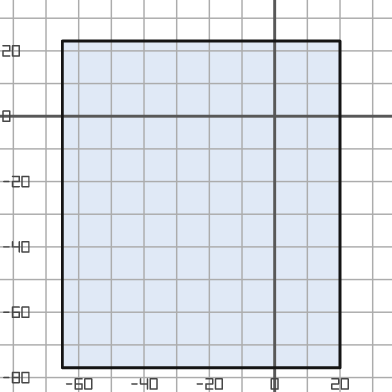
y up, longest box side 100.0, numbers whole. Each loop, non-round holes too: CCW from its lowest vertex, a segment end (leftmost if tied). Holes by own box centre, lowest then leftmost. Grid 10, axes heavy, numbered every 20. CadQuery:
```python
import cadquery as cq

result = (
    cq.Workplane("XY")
    .moveTo(-65.0, -77.0)
    .lineTo(20.0, -77.0)
    .lineTo(20.0, 23.0)
    .lineTo(-65.0, 23.0)
    .close()
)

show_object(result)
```